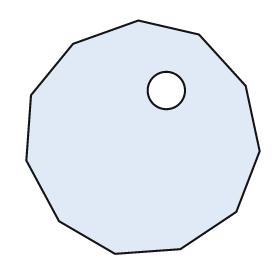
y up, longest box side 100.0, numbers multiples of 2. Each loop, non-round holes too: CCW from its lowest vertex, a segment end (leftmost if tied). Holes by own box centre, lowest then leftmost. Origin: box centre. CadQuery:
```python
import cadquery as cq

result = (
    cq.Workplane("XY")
    .moveTo(-12.0, -50.0)
    .lineTo(16.0, -48.0)
    .lineTo(40.0, -32.0)
    .lineTo(50.0, -6.0)
    .lineTo(44.0, 22.0)
    .lineTo(24.0, 44.0)
    .lineTo(-2.0, 50.0)
    .lineTo(-30.0, 40.0)
    .lineTo(-48.0, 18.0)
    .lineTo(-50.0, -10.0)
    .lineTo(-36.0, -36.0)
    .close()
    .moveTo(10.0, 20.0)
    .circle(8.0)
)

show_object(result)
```